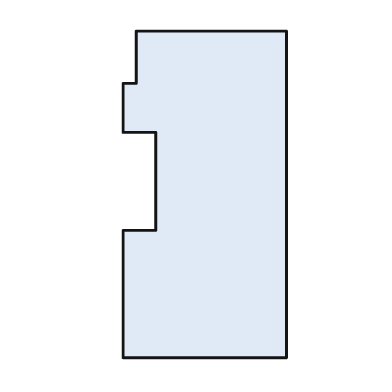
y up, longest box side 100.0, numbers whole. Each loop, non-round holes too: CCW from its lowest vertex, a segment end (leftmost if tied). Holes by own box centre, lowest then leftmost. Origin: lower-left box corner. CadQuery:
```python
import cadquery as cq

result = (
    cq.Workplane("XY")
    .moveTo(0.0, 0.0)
    .lineTo(50.0, 0.0)
    .lineTo(50.0, 100.0)
    .lineTo(4.0, 100.0)
    .lineTo(4.0, 84.0)
    .lineTo(0.0, 84.0)
    .lineTo(0.0, 69.0)
    .lineTo(10.0, 69.0)
    .lineTo(10.0, 39.0)
    .lineTo(0.0, 39.0)
    .close()
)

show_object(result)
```